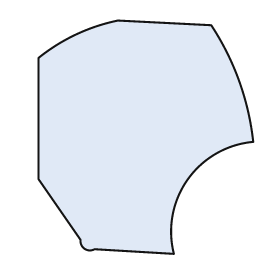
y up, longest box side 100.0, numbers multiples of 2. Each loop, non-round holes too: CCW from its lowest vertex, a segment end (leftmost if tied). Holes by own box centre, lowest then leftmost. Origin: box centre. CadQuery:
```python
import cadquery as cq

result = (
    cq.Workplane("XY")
    .moveTo(12.0, -50.0)
    .threePointArc((18.0, -18.0), (46.0, -2.0))
    .threePointArc((40.0, 24.0), (28.0, 48.0))
    .lineTo(-12.0, 50.0)
    .threePointArc((-30.0, 44.0), (-46.0, 34.0))
    .lineTo(-46.0, -18.0)
    .lineTo(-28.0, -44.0)
    .threePointArc((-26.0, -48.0), (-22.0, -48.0))
    .close()
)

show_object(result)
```